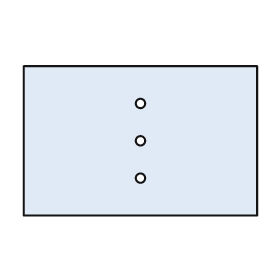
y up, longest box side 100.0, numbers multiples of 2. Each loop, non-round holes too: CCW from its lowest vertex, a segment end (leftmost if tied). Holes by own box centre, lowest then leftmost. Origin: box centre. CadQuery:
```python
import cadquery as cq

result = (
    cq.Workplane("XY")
    .moveTo(-50.0, -32.0)
    .lineTo(50.0, -32.0)
    .lineTo(50.0, 32.0)
    .lineTo(-50.0, 32.0)
    .close()
    .moveTo(0.0, -16.0)
    .circle(2.0)
    .moveTo(0.0, 0.0)
    .circle(2.0)
    .moveTo(0.0, 16.0)
    .circle(2.0)
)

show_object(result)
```